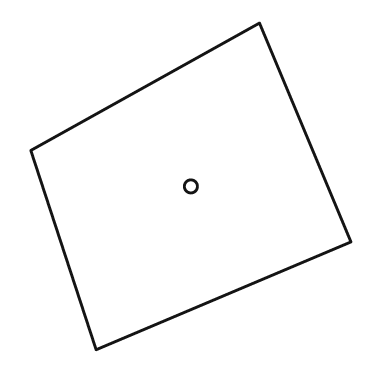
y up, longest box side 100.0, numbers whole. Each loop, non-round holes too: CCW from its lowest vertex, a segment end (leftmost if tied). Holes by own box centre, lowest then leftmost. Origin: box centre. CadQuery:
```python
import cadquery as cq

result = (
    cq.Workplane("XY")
    .moveTo(-29.0, -50.0)
    .lineTo(49.0, -17.0)
    .lineTo(21.0, 50.0)
    .lineTo(-49.0, 11.0)
    .close()
    .moveTo(0.0, 0.0)
    .circle(2.0)
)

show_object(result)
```